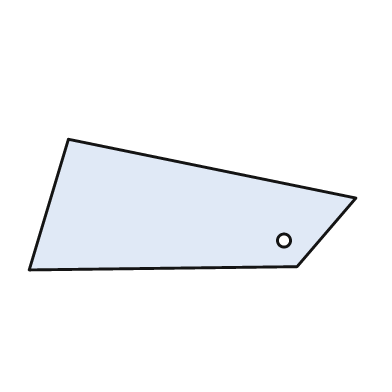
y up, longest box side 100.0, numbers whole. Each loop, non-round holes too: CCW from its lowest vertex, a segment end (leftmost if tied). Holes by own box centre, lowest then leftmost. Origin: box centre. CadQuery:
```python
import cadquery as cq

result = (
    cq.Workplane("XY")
    .moveTo(-50.0, -20.0)
    .lineTo(32.0, -19.0)
    .lineTo(50.0, 2.0)
    .lineTo(-38.0, 20.0)
    .close()
    .moveTo(28.0, -11.0)
    .circle(2.0)
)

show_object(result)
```